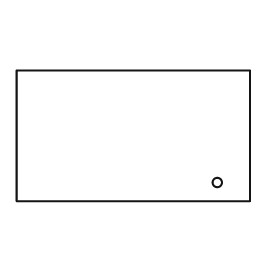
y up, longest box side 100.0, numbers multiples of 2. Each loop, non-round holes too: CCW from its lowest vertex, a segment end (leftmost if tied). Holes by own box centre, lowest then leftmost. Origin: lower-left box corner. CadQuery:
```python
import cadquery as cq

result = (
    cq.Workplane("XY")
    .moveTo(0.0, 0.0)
    .lineTo(100.0, 0.0)
    .lineTo(100.0, 56.0)
    .lineTo(0.0, 56.0)
    .close()
    .moveTo(86.0, 8.0)
    .circle(2.0)
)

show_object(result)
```